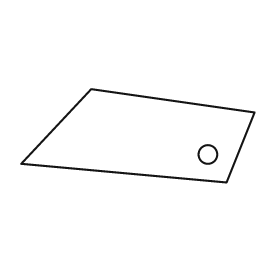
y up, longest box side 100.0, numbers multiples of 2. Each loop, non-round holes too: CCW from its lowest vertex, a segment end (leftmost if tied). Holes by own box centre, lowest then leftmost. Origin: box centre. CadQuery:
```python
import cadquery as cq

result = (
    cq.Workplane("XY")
    .moveTo(38.0, -20.0)
    .lineTo(50.0, 10.0)
    .lineTo(-20.0, 20.0)
    .lineTo(-50.0, -12.0)
    .close()
    .moveTo(30.0, -8.0)
    .circle(4.0)
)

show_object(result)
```